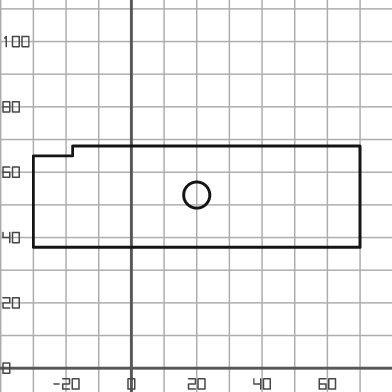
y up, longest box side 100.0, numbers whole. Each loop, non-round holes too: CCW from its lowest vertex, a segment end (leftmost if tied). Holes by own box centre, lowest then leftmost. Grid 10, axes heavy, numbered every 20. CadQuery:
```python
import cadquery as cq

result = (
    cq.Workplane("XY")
    .moveTo(-30.0, 37.0)
    .lineTo(70.0, 37.0)
    .lineTo(70.0, 68.0)
    .lineTo(-18.0, 68.0)
    .lineTo(-18.0, 65.0)
    .lineTo(-30.0, 65.0)
    .close()
    .moveTo(20.0, 53.0)
    .circle(4.0)
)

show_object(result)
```